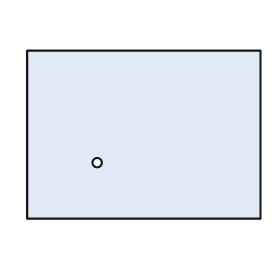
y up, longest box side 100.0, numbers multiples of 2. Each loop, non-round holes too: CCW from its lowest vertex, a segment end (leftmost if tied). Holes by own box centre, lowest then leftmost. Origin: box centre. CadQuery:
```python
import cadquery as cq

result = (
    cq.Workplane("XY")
    .moveTo(-50.0, -36.0)
    .lineTo(50.0, -36.0)
    .lineTo(50.0, 36.0)
    .lineTo(-50.0, 36.0)
    .close()
    .moveTo(-20.0, -12.0)
    .circle(2.0)
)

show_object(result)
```